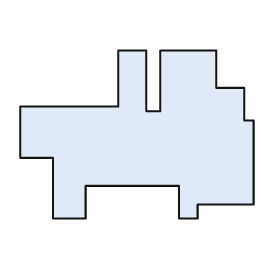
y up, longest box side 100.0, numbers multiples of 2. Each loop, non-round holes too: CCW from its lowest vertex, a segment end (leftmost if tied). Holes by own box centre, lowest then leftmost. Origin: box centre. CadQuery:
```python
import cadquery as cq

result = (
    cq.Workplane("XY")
    .moveTo(-36.0, -36.0)
    .lineTo(-22.0, -36.0)
    .lineTo(-22.0, -22.0)
    .lineTo(18.0, -22.0)
    .lineTo(18.0, -36.0)
    .lineTo(26.0, -36.0)
    .lineTo(26.0, -30.0)
    .lineTo(50.0, -30.0)
    .lineTo(50.0, 6.0)
    .lineTo(46.0, 6.0)
    .lineTo(46.0, 20.0)
    .lineTo(34.0, 20.0)
    .lineTo(34.0, 36.0)
    .lineTo(10.0, 36.0)
    .lineTo(10.0, 10.0)
    .lineTo(4.0, 10.0)
    .lineTo(4.0, 36.0)
    .lineTo(-8.0, 36.0)
    .lineTo(-8.0, 12.0)
    .lineTo(-50.0, 12.0)
    .lineTo(-50.0, -10.0)
    .lineTo(-36.0, -10.0)
    .close()
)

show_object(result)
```